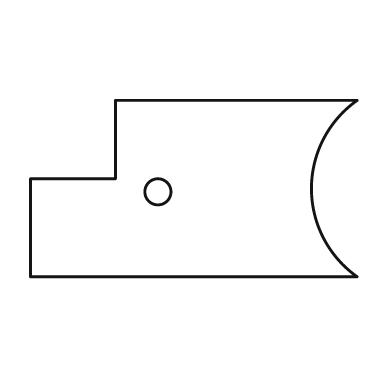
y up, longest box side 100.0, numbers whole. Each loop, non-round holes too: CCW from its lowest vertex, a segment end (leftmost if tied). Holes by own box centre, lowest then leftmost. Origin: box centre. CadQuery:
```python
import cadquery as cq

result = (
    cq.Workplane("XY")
    .moveTo(-50.0, -27.0)
    .lineTo(50.0, -27.0)
    .threePointArc((36.0, 0.0), (50.0, 27.0))
    .lineTo(-24.0, 27.0)
    .lineTo(-24.0, 3.0)
    .lineTo(-50.0, 3.0)
    .close()
    .moveTo(-11.0, -1.0)
    .circle(4.0)
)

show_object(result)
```